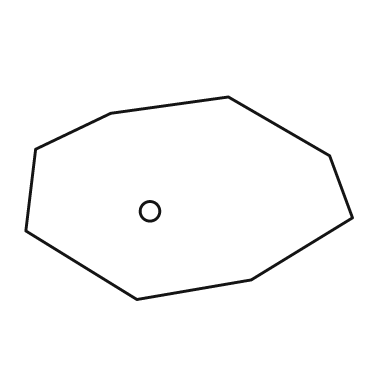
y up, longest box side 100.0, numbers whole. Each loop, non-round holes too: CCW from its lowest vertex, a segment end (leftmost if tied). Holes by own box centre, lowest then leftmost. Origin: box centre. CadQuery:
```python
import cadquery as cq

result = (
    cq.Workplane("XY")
    .moveTo(-16.0, -31.0)
    .lineTo(19.0, -25.0)
    .lineTo(50.0, -6.0)
    .lineTo(43.0, 13.0)
    .lineTo(12.0, 31.0)
    .lineTo(-24.0, 26.0)
    .lineTo(-47.0, 15.0)
    .lineTo(-50.0, -10.0)
    .close()
    .moveTo(-12.0, -4.0)
    .circle(3.0)
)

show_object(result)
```